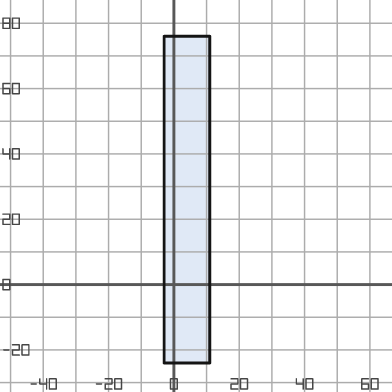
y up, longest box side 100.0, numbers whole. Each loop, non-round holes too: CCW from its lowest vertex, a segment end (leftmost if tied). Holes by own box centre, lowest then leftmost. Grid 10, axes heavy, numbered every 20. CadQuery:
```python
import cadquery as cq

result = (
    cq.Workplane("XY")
    .moveTo(-3.0, -24.0)
    .lineTo(11.0, -24.0)
    .lineTo(11.0, 76.0)
    .lineTo(-3.0, 76.0)
    .close()
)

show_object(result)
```